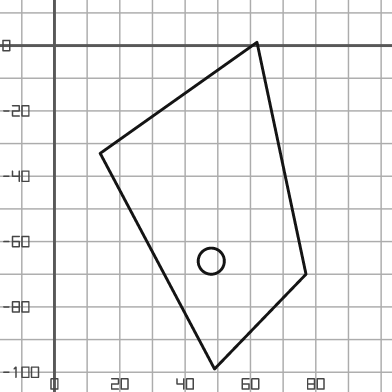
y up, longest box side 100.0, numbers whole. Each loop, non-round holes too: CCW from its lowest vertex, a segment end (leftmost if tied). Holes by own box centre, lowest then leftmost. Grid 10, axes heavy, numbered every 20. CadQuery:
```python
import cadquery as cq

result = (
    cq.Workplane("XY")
    .moveTo(49.0, -99.0)
    .lineTo(77.0, -70.0)
    .lineTo(62.0, 1.0)
    .lineTo(14.0, -33.0)
    .close()
    .moveTo(48.0, -66.0)
    .circle(4.0)
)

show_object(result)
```